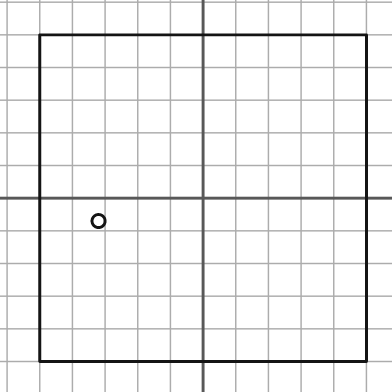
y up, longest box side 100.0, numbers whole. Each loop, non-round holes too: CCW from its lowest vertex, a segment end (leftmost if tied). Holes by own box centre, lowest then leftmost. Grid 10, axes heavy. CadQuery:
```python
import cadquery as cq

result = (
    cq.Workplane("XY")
    .moveTo(-50.0, -50.0)
    .lineTo(50.0, -50.0)
    .lineTo(50.0, 50.0)
    .lineTo(-50.0, 50.0)
    .close()
    .moveTo(-32.0, -7.0)
    .circle(2.0)
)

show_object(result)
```